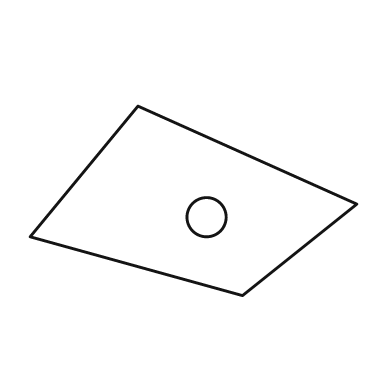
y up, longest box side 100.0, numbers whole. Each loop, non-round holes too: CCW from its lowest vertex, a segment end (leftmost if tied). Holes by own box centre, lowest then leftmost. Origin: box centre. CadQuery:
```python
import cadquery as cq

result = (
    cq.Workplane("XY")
    .moveTo(15.0, -29.0)
    .lineTo(50.0, -1.0)
    .lineTo(-17.0, 29.0)
    .lineTo(-50.0, -11.0)
    .close()
    .moveTo(4.0, -5.0)
    .circle(6.0)
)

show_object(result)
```